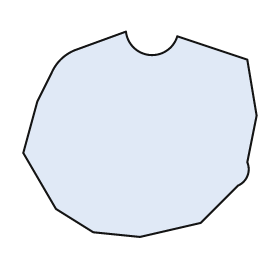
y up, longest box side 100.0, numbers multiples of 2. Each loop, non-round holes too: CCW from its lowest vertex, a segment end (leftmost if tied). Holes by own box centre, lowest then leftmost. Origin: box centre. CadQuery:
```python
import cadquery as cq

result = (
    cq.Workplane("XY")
    .moveTo(0.0, -44.0)
    .lineTo(26.0, -38.0)
    .lineTo(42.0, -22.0)
    .threePointArc((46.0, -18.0), (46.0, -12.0))
    .lineTo(50.0, 8.0)
    .lineTo(46.0, 32.0)
    .lineTo(16.0, 42.0)
    .threePointArc((4.0, 34.0), (-6.0, 44.0))
    .lineTo(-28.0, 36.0)
    .threePointArc((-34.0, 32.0), (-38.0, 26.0))
    .lineTo(-44.0, 14.0)
    .lineTo(-50.0, -8.0)
    .lineTo(-36.0, -32.0)
    .lineTo(-20.0, -42.0)
    .close()
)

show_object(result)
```